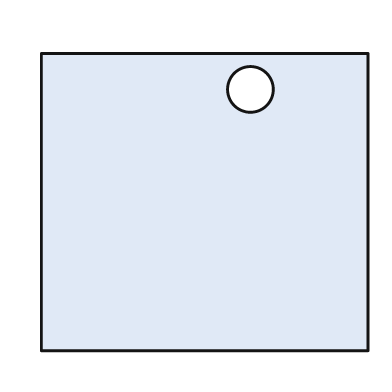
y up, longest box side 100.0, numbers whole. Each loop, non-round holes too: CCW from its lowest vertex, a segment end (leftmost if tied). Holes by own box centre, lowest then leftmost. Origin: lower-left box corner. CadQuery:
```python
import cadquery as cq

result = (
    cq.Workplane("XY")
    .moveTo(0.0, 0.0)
    .lineTo(100.0, 0.0)
    .lineTo(100.0, 91.0)
    .lineTo(0.0, 91.0)
    .close()
    .moveTo(64.0, 80.0)
    .circle(7.0)
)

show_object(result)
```